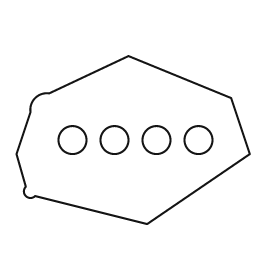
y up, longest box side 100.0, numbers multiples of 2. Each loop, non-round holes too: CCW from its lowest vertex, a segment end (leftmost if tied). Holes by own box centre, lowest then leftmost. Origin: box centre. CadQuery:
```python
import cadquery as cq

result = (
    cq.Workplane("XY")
    .moveTo(6.0, -36.0)
    .lineTo(50.0, -6.0)
    .lineTo(42.0, 18.0)
    .lineTo(-2.0, 36.0)
    .lineTo(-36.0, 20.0)
    .threePointArc((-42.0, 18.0), (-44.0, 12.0))
    .lineTo(-50.0, -6.0)
    .lineTo(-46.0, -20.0)
    .threePointArc((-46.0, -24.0), (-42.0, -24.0))
    .close()
    .moveTo(-26.0, 0.0)
    .circle(6.0)
    .moveTo(-8.0, 0.0)
    .circle(6.0)
    .moveTo(10.0, 0.0)
    .circle(6.0)
    .moveTo(28.0, 0.0)
    .circle(6.0)
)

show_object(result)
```